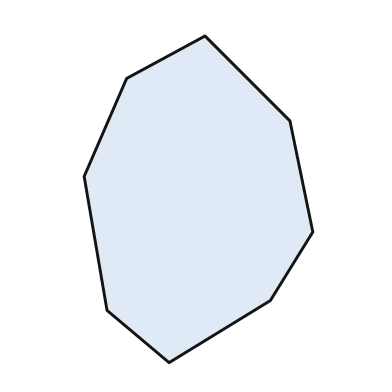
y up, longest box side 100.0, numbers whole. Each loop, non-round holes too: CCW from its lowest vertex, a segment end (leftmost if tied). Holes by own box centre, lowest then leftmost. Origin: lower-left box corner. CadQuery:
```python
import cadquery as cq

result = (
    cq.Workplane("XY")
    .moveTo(26.0, 0.0)
    .lineTo(57.0, 19.0)
    .lineTo(70.0, 40.0)
    .lineTo(63.0, 74.0)
    .lineTo(37.0, 100.0)
    .lineTo(13.0, 87.0)
    .lineTo(0.0, 57.0)
    .lineTo(7.0, 16.0)
    .close()
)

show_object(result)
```